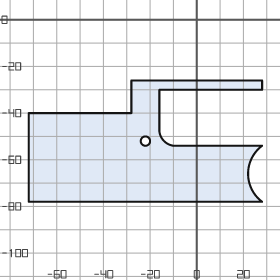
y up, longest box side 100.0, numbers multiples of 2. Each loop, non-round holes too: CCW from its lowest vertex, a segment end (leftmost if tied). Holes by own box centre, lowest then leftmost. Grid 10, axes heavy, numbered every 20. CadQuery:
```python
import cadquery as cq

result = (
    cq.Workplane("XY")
    .moveTo(-72.0, -78.0)
    .lineTo(28.0, -78.0)
    .threePointArc((22.0, -66.0), (28.0, -54.0))
    .lineTo(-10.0, -54.0)
    .threePointArc((-14.0, -52.0), (-16.0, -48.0))
    .lineTo(-16.0, -30.0)
    .lineTo(28.0, -30.0)
    .lineTo(28.0, -26.0)
    .lineTo(-28.0, -26.0)
    .lineTo(-28.0, -40.0)
    .lineTo(-72.0, -40.0)
    .close()
    .moveTo(-22.0, -52.0)
    .circle(2.0)
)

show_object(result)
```